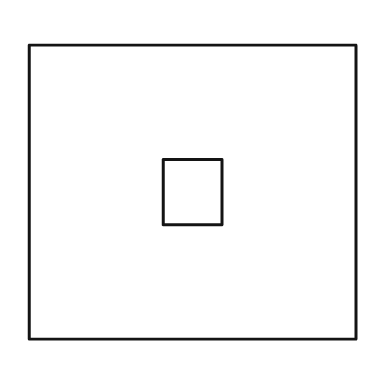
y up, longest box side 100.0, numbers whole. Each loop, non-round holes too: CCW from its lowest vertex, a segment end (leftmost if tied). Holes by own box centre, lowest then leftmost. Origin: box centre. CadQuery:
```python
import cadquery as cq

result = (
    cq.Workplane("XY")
    .moveTo(-50.0, -45.0)
    .lineTo(50.0, -45.0)
    .lineTo(50.0, 45.0)
    .lineTo(-50.0, 45.0)
    .close()
    .moveTo(-9.0, -10.0)
    .lineTo(9.0, -10.0)
    .lineTo(9.0, 10.0)
    .lineTo(-9.0, 10.0)
    .close()
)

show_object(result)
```